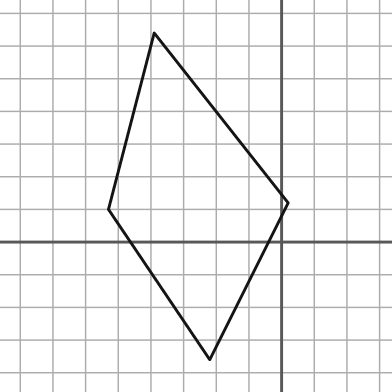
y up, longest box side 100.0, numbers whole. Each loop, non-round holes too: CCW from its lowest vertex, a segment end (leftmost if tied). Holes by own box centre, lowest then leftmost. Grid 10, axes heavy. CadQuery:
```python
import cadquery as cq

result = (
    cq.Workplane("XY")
    .moveTo(-22.0, -36.0)
    .lineTo(2.0, 12.0)
    .lineTo(-39.0, 64.0)
    .lineTo(-53.0, 10.0)
    .close()
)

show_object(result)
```